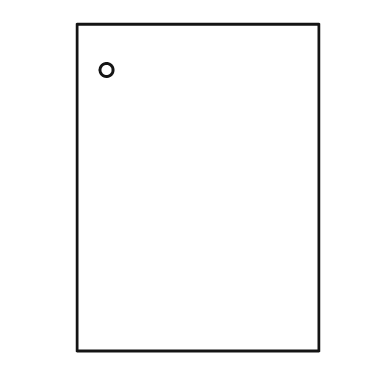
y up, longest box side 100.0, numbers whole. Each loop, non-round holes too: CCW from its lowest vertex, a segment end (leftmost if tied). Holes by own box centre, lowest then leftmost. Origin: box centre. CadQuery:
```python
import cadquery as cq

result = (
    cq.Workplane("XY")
    .moveTo(-37.0, -50.0)
    .lineTo(37.0, -50.0)
    .lineTo(37.0, 50.0)
    .lineTo(-37.0, 50.0)
    .close()
    .moveTo(-28.0, 36.0)
    .circle(2.0)
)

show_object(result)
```